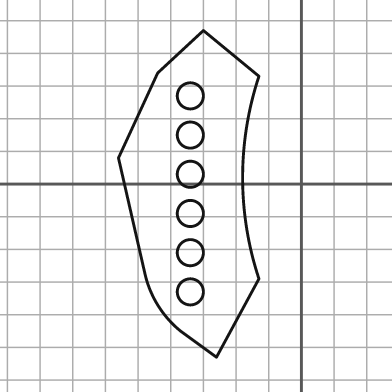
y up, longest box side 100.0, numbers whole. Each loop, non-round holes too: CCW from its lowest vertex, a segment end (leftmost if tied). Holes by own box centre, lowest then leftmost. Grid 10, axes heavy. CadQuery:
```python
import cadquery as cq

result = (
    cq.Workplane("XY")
    .moveTo(-26.0, -53.0)
    .lineTo(-13.0, -29.0)
    .threePointArc((-18.0, 2.0), (-13.0, 33.0))
    .lineTo(-30.0, 47.0)
    .lineTo(-44.0, 34.0)
    .lineTo(-56.0, 8.0)
    .lineTo(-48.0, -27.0)
    .threePointArc((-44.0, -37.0), (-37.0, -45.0))
    .close()
    .moveTo(-34.0, -33.0)
    .circle(4.0)
    .moveTo(-34.0, -21.0)
    .circle(4.0)
    .moveTo(-34.0, -9.0)
    .circle(4.0)
    .moveTo(-34.0, 3.0)
    .circle(4.0)
    .moveTo(-34.0, 15.0)
    .circle(4.0)
    .moveTo(-34.0, 27.0)
    .circle(4.0)
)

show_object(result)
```